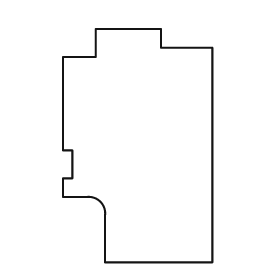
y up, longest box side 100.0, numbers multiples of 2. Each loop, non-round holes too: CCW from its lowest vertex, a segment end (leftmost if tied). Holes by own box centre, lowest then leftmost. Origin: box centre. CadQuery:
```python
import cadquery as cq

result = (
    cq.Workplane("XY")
    .moveTo(-14.0, -50.0)
    .lineTo(32.0, -50.0)
    .lineTo(32.0, 42.0)
    .lineTo(10.0, 42.0)
    .lineTo(10.0, 50.0)
    .lineTo(-18.0, 50.0)
    .lineTo(-18.0, 38.0)
    .lineTo(-32.0, 38.0)
    .lineTo(-32.0, -2.0)
    .lineTo(-28.0, -2.0)
    .lineTo(-28.0, -14.0)
    .lineTo(-32.0, -14.0)
    .lineTo(-32.0, -22.0)
    .lineTo(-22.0, -22.0)
    .threePointArc((-16.0, -24.0), (-14.0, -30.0))
    .close()
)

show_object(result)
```